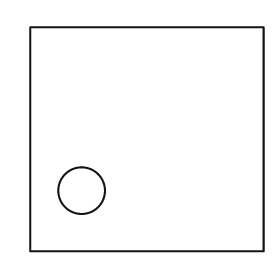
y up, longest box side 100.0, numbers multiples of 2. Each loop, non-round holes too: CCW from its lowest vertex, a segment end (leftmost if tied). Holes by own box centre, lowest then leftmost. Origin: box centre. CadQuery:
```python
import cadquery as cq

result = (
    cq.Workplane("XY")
    .moveTo(-50.0, -48.0)
    .lineTo(50.0, -48.0)
    .lineTo(50.0, 48.0)
    .lineTo(-50.0, 48.0)
    .close()
    .moveTo(-28.0, -22.0)
    .circle(10.0)
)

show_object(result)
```